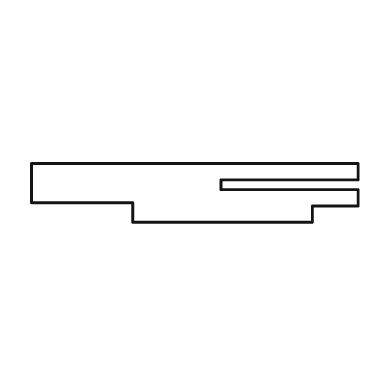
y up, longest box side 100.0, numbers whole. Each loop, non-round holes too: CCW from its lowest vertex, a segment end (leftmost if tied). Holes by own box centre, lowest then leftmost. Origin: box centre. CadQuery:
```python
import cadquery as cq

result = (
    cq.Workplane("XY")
    .moveTo(-19.0, -9.0)
    .lineTo(36.0, -9.0)
    .lineTo(36.0, -4.0)
    .lineTo(50.0, -4.0)
    .lineTo(50.0, 1.0)
    .lineTo(8.0, 1.0)
    .lineTo(8.0, 4.0)
    .lineTo(50.0, 4.0)
    .lineTo(50.0, 9.0)
    .lineTo(-50.0, 9.0)
    .lineTo(-50.0, -3.0)
    .lineTo(-19.0, -3.0)
    .close()
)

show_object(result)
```